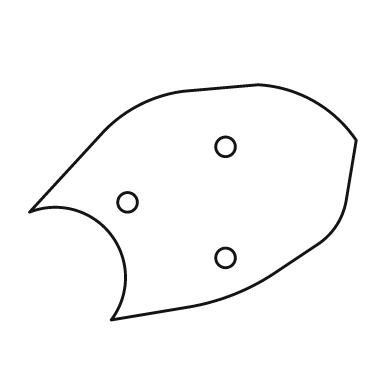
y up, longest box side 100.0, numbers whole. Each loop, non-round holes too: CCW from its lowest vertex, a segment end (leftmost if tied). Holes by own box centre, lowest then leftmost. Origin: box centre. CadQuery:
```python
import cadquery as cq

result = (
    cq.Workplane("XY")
    .moveTo(-25.0, -36.0)
    .lineTo(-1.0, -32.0)
    .threePointArc((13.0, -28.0), (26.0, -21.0))
    .lineTo(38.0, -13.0)
    .threePointArc((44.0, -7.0), (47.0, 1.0))
    .lineTo(50.0, 19.0)
    .threePointArc((37.0, 31.0), (20.0, 36.0))
    .lineTo(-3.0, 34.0)
    .threePointArc((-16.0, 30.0), (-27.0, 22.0))
    .lineTo(-50.0, -3.0)
    .threePointArc((-25.0, -10.0), (-25.0, -36.0))
    .close()
    .moveTo(10.0, -17.0)
    .circle(3.0)
    .moveTo(-20.0, 0.0)
    .circle(3.0)
    .moveTo(10.0, 17.0)
    .circle(3.0)
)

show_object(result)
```